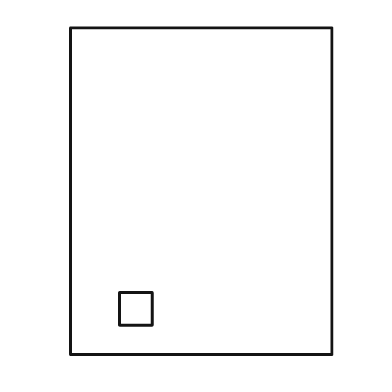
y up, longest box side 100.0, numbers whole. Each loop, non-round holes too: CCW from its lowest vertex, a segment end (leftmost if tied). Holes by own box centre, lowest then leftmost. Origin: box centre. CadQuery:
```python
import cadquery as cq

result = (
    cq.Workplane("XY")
    .moveTo(-40.0, -50.0)
    .lineTo(40.0, -50.0)
    .lineTo(40.0, 50.0)
    .lineTo(-40.0, 50.0)
    .close()
    .moveTo(-25.0, -41.0)
    .lineTo(-15.0, -41.0)
    .lineTo(-15.0, -31.0)
    .lineTo(-25.0, -31.0)
    .close()
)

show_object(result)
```